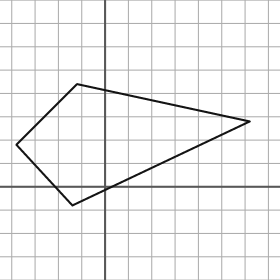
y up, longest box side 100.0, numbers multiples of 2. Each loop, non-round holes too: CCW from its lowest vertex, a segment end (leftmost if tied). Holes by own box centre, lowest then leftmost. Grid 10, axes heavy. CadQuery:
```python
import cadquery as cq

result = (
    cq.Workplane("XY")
    .moveTo(-14.0, -8.0)
    .lineTo(62.0, 28.0)
    .lineTo(-12.0, 44.0)
    .lineTo(-38.0, 18.0)
    .close()
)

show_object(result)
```